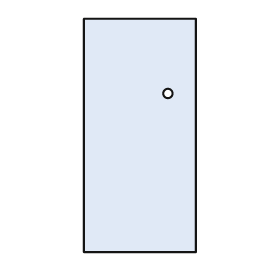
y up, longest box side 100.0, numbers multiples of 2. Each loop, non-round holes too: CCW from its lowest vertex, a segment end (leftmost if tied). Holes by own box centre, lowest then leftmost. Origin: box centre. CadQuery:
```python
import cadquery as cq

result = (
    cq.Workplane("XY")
    .moveTo(-24.0, -50.0)
    .lineTo(24.0, -50.0)
    .lineTo(24.0, 50.0)
    .lineTo(-24.0, 50.0)
    .close()
    .moveTo(12.0, 18.0)
    .circle(2.0)
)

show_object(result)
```